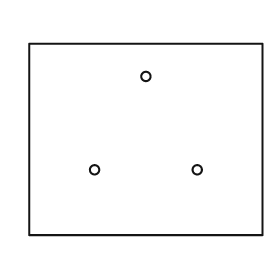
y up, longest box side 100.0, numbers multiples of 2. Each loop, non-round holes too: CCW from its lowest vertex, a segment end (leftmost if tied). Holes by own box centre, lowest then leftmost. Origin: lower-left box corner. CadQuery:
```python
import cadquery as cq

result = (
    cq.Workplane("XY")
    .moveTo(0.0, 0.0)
    .lineTo(100.0, 0.0)
    .lineTo(100.0, 82.0)
    .lineTo(0.0, 82.0)
    .close()
    .moveTo(28.0, 28.0)
    .circle(2.0)
    .moveTo(72.0, 28.0)
    .circle(2.0)
    .moveTo(50.0, 68.0)
    .circle(2.0)
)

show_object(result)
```